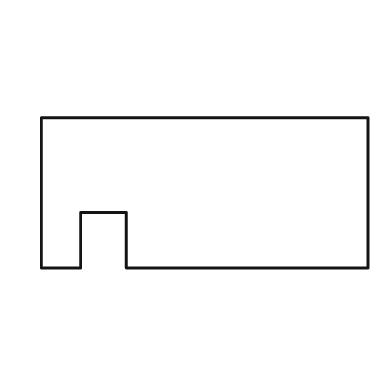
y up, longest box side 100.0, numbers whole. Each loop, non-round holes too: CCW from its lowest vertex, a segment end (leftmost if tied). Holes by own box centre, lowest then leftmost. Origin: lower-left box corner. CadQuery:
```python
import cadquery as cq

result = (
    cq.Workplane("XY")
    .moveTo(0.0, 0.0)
    .lineTo(12.0, 0.0)
    .lineTo(12.0, 17.0)
    .lineTo(26.0, 17.0)
    .lineTo(26.0, 0.0)
    .lineTo(100.0, 0.0)
    .lineTo(100.0, 46.0)
    .lineTo(0.0, 46.0)
    .close()
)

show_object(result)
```